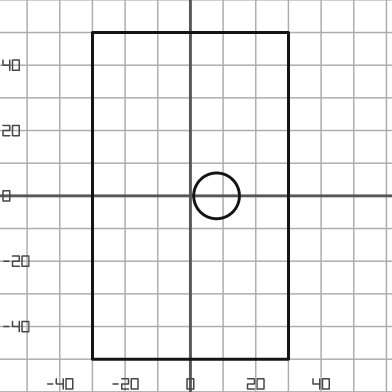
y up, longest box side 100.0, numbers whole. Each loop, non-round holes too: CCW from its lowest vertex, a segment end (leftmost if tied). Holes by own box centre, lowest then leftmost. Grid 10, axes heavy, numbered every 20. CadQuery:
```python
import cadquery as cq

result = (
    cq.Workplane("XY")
    .moveTo(-30.0, -50.0)
    .lineTo(30.0, -50.0)
    .lineTo(30.0, 50.0)
    .lineTo(-30.0, 50.0)
    .close()
    .moveTo(8.0, 0.0)
    .circle(7.0)
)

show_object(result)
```